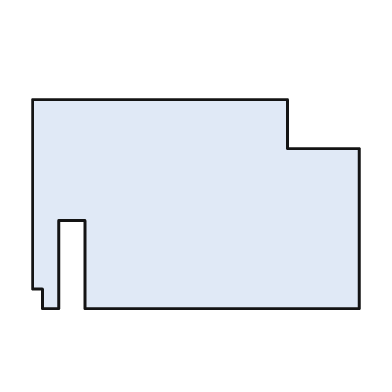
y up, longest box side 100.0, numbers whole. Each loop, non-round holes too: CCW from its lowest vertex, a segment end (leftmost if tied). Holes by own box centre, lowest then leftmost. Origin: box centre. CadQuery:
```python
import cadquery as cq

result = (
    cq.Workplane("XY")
    .moveTo(-47.0, -32.0)
    .lineTo(-42.0, -32.0)
    .lineTo(-42.0, -5.0)
    .lineTo(-34.0, -5.0)
    .lineTo(-34.0, -32.0)
    .lineTo(50.0, -32.0)
    .lineTo(50.0, 17.0)
    .lineTo(28.0, 17.0)
    .lineTo(28.0, 32.0)
    .lineTo(-50.0, 32.0)
    .lineTo(-50.0, -26.0)
    .lineTo(-47.0, -26.0)
    .close()
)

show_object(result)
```